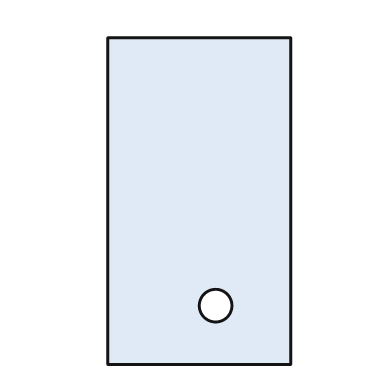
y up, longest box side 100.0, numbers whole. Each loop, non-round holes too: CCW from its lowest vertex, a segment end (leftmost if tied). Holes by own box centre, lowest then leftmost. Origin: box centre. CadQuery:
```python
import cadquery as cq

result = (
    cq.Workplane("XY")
    .moveTo(-28.0, -50.0)
    .lineTo(28.0, -50.0)
    .lineTo(28.0, 50.0)
    .lineTo(-28.0, 50.0)
    .close()
    .moveTo(5.0, -32.0)
    .circle(5.0)
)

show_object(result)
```